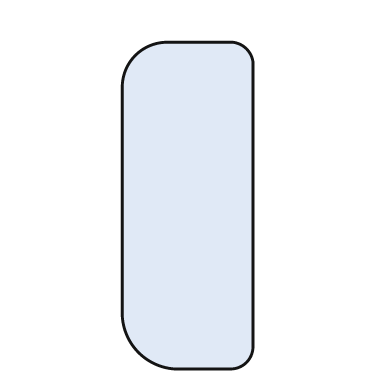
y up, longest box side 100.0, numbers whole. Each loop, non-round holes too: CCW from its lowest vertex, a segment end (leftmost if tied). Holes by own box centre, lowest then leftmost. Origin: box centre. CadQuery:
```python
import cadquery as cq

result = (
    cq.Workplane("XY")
    .moveTo(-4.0, -50.0)
    .lineTo(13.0, -50.0)
    .threePointArc((18.0, -48.0), (20.0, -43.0))
    .lineTo(20.0, 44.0)
    .threePointArc((18.0, 48.0), (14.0, 50.0))
    .lineTo(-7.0, 50.0)
    .threePointArc((-16.0, 46.0), (-20.0, 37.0))
    .lineTo(-20.0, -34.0)
    .threePointArc((-15.0, -45.0), (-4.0, -50.0))
    .close()
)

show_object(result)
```